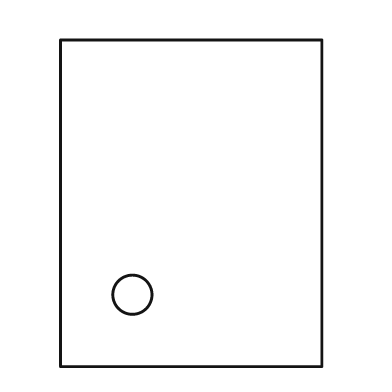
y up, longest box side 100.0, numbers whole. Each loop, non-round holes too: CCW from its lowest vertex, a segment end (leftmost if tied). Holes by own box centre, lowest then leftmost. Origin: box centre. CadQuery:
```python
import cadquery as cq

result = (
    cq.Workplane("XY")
    .moveTo(-40.0, -50.0)
    .lineTo(40.0, -50.0)
    .lineTo(40.0, 50.0)
    .lineTo(-40.0, 50.0)
    .close()
    .moveTo(-18.0, -28.0)
    .circle(6.0)
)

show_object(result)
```